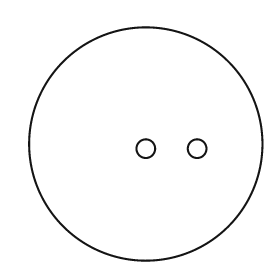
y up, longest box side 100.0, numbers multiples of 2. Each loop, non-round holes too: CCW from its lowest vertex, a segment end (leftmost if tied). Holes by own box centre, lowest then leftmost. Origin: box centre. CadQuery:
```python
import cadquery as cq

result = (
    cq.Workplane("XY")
    .moveTo(0.0, 0.0)
    .circle(50.0)
    .moveTo(0.0, -2.0)
    .circle(4.0)
    .moveTo(22.0, -2.0)
    .circle(4.0)
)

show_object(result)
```